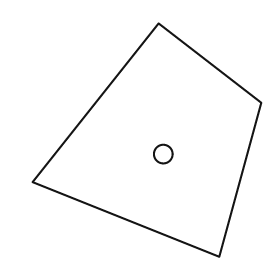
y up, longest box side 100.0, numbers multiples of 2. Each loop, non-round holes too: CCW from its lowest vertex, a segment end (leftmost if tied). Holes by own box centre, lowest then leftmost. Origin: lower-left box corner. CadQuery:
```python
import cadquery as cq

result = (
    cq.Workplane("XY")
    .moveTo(80.0, 0.0)
    .lineTo(98.0, 66.0)
    .lineTo(54.0, 100.0)
    .lineTo(0.0, 32.0)
    .close()
    .moveTo(56.0, 44.0)
    .circle(4.0)
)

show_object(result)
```